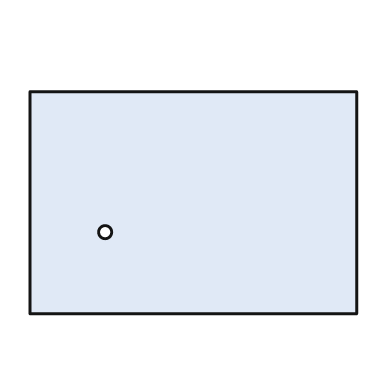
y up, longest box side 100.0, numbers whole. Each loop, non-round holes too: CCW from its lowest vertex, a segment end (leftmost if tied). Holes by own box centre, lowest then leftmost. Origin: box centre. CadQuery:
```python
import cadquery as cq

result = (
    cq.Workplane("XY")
    .moveTo(-50.0, -34.0)
    .lineTo(50.0, -34.0)
    .lineTo(50.0, 34.0)
    .lineTo(-50.0, 34.0)
    .close()
    .moveTo(-27.0, -9.0)
    .circle(2.0)
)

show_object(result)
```